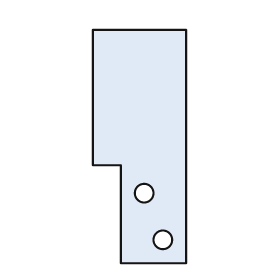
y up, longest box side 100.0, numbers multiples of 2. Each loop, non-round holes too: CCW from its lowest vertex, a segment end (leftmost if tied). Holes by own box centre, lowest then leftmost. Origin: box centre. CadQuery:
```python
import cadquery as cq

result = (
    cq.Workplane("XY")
    .moveTo(-8.0, -50.0)
    .lineTo(20.0, -50.0)
    .lineTo(20.0, 50.0)
    .lineTo(-20.0, 50.0)
    .lineTo(-20.0, -8.0)
    .lineTo(-8.0, -8.0)
    .close()
    .moveTo(10.0, -40.0)
    .circle(4.0)
    .moveTo(2.0, -20.0)
    .circle(4.0)
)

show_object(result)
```